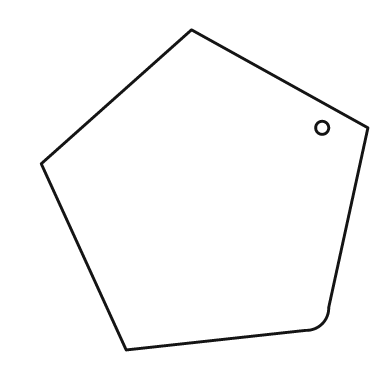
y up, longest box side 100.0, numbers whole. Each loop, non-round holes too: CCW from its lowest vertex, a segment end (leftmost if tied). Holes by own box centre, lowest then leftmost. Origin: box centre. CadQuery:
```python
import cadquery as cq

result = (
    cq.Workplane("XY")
    .moveTo(-24.0, -49.0)
    .lineTo(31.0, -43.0)
    .threePointArc((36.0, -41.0), (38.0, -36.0))
    .lineTo(50.0, 19.0)
    .lineTo(-4.0, 49.0)
    .lineTo(-50.0, 8.0)
    .close()
    .moveTo(36.0, 19.0)
    .circle(2.0)
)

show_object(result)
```